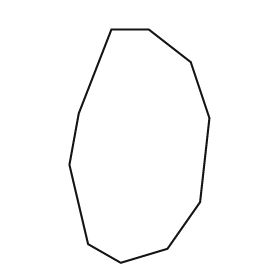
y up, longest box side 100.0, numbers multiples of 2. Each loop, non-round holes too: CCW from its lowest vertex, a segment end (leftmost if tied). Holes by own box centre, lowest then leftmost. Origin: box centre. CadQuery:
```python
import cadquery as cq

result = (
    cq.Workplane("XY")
    .moveTo(-8.0, -50.0)
    .lineTo(12.0, -44.0)
    .lineTo(26.0, -24.0)
    .lineTo(30.0, 12.0)
    .lineTo(22.0, 36.0)
    .lineTo(4.0, 50.0)
    .lineTo(-12.0, 50.0)
    .lineTo(-26.0, 14.0)
    .lineTo(-30.0, -8.0)
    .lineTo(-22.0, -42.0)
    .close()
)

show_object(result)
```